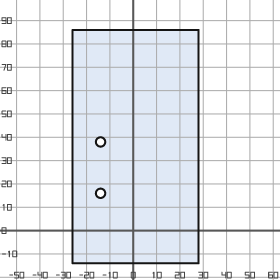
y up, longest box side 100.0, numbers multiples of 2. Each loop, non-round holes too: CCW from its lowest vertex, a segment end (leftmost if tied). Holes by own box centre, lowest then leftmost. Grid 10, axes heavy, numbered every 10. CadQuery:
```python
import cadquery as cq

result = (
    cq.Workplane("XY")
    .moveTo(-26.0, -14.0)
    .lineTo(28.0, -14.0)
    .lineTo(28.0, 86.0)
    .lineTo(-26.0, 86.0)
    .close()
    .moveTo(-14.0, 16.0)
    .circle(2.0)
    .moveTo(-14.0, 38.0)
    .circle(2.0)
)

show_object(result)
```